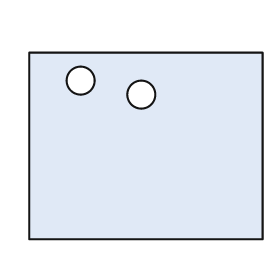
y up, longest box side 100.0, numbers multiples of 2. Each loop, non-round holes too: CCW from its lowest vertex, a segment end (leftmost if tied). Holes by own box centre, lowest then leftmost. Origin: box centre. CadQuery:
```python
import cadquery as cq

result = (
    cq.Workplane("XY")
    .moveTo(-50.0, -40.0)
    .lineTo(50.0, -40.0)
    .lineTo(50.0, 40.0)
    .lineTo(-50.0, 40.0)
    .close()
    .moveTo(-2.0, 22.0)
    .circle(6.0)
    .moveTo(-28.0, 28.0)
    .circle(6.0)
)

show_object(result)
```